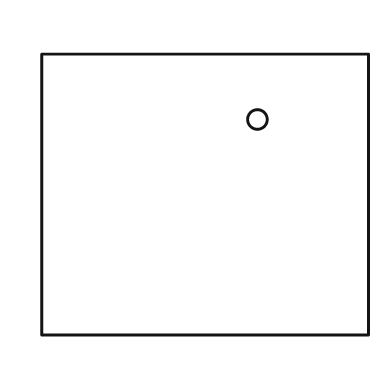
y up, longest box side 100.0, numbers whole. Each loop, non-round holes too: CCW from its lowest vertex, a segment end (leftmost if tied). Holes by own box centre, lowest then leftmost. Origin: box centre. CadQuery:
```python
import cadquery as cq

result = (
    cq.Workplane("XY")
    .moveTo(-50.0, -43.0)
    .lineTo(50.0, -43.0)
    .lineTo(50.0, 43.0)
    .lineTo(-50.0, 43.0)
    .close()
    .moveTo(16.0, 23.0)
    .circle(3.0)
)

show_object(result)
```